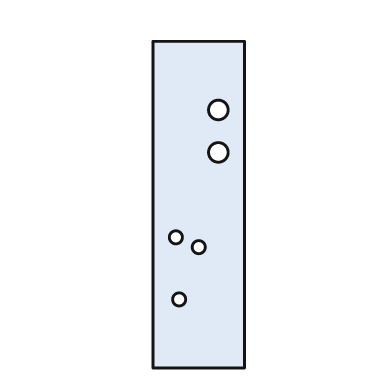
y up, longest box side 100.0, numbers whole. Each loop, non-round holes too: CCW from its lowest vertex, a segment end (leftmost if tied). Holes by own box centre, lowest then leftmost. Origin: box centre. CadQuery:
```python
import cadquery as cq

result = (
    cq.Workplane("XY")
    .moveTo(-14.0, -50.0)
    .lineTo(14.0, -50.0)
    .lineTo(14.0, 50.0)
    .lineTo(-14.0, 50.0)
    .close()
    .moveTo(-6.0, -29.0)
    .circle(2.0)
    .moveTo(0.0, -13.0)
    .circle(2.0)
    .moveTo(-7.0, -10.0)
    .circle(2.0)
    .moveTo(6.0, 16.0)
    .circle(3.0)
    .moveTo(6.0, 29.0)
    .circle(3.0)
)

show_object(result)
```